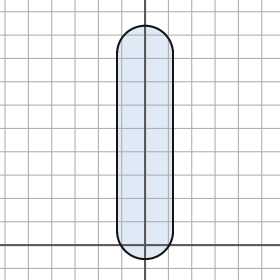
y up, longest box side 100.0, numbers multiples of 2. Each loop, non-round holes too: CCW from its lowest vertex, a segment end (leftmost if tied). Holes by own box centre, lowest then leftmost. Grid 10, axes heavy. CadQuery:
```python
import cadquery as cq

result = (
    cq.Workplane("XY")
    .moveTo(-12.0, 6.0)
    .threePointArc((0.0, -6.0), (12.0, 6.0))
    .lineTo(12.0, 82.0)
    .threePointArc((0.0, 94.0), (-12.0, 82.0))
    .close()
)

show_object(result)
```